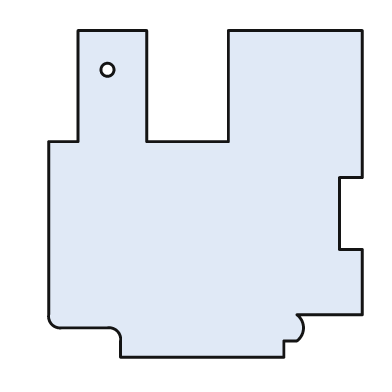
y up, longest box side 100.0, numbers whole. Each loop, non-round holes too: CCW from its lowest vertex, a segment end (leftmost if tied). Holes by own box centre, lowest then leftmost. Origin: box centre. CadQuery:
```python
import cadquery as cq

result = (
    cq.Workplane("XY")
    .moveTo(-26.0, -50.0)
    .lineTo(24.0, -50.0)
    .lineTo(24.0, -45.0)
    .lineTo(28.0, -45.0)
    .threePointArc((30.0, -41.0), (28.0, -37.0))
    .lineTo(48.0, -37.0)
    .lineTo(48.0, -17.0)
    .lineTo(41.0, -17.0)
    .lineTo(41.0, 5.0)
    .lineTo(48.0, 5.0)
    .lineTo(48.0, 50.0)
    .lineTo(7.0, 50.0)
    .lineTo(7.0, 16.0)
    .lineTo(-18.0, 16.0)
    .lineTo(-18.0, 50.0)
    .lineTo(-39.0, 50.0)
    .lineTo(-39.0, 16.0)
    .lineTo(-48.0, 16.0)
    .lineTo(-48.0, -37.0)
    .threePointArc((-47.0, -40.0), (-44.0, -41.0))
    .lineTo(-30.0, -41.0)
    .threePointArc((-27.0, -42.0), (-26.0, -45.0))
    .close()
    .moveTo(-30.0, 38.0)
    .circle(2.0)
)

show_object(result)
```